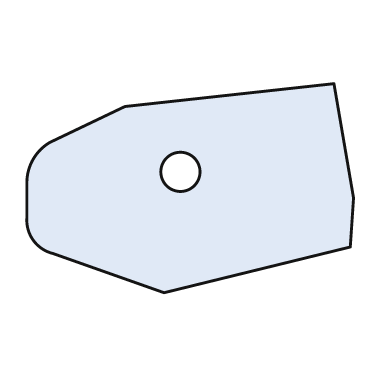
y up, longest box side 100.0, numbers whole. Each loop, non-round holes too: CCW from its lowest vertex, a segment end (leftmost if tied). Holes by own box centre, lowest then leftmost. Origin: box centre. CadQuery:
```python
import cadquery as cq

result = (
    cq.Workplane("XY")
    .moveTo(-8.0, -32.0)
    .lineTo(49.0, -18.0)
    .lineTo(50.0, -3.0)
    .lineTo(44.0, 32.0)
    .lineTo(-20.0, 25.0)
    .lineTo(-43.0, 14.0)
    .threePointArc((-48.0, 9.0), (-50.0, 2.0))
    .lineTo(-50.0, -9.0)
    .threePointArc((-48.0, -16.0), (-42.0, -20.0))
    .close()
    .moveTo(-3.0, 5.0)
    .circle(6.0)
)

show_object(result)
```